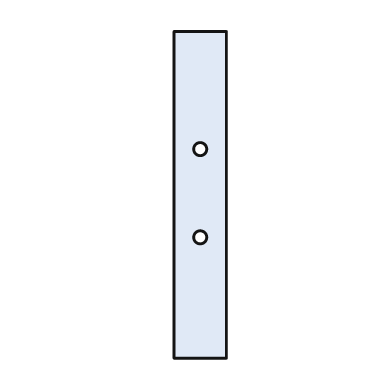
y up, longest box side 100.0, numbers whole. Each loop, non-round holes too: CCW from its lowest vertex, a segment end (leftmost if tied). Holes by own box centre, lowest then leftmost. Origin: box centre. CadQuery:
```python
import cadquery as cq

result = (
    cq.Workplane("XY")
    .moveTo(-8.0, -50.0)
    .lineTo(8.0, -50.0)
    .lineTo(8.0, 50.0)
    .lineTo(-8.0, 50.0)
    .close()
    .moveTo(0.0, -13.0)
    .circle(2.0)
    .moveTo(0.0, 14.0)
    .circle(2.0)
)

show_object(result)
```